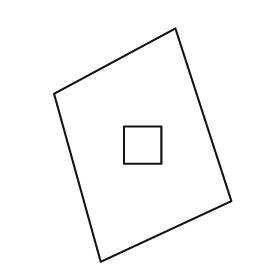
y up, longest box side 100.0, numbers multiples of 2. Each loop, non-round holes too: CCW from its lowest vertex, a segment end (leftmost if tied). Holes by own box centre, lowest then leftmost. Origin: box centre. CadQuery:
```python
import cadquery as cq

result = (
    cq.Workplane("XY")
    .moveTo(-18.0, -50.0)
    .lineTo(38.0, -24.0)
    .lineTo(14.0, 50.0)
    .lineTo(-38.0, 22.0)
    .close()
    .moveTo(-8.0, -8.0)
    .lineTo(8.0, -8.0)
    .lineTo(8.0, 8.0)
    .lineTo(-8.0, 8.0)
    .close()
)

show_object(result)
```